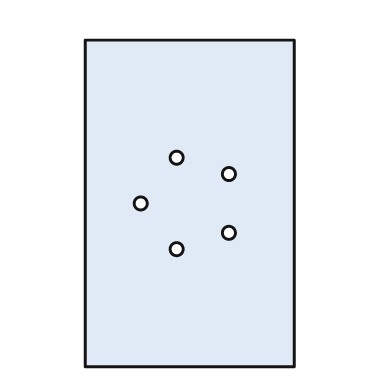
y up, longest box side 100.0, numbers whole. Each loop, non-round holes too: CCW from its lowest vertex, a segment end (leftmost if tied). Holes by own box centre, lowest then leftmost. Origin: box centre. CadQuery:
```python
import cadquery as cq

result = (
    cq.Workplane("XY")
    .moveTo(-32.0, -50.0)
    .lineTo(32.0, -50.0)
    .lineTo(32.0, 50.0)
    .lineTo(-32.0, 50.0)
    .close()
    .moveTo(-4.0, -14.0)
    .circle(2.0)
    .moveTo(12.0, -9.0)
    .circle(2.0)
    .moveTo(-15.0, 0.0)
    .circle(2.0)
    .moveTo(12.0, 9.0)
    .circle(2.0)
    .moveTo(-4.0, 14.0)
    .circle(2.0)
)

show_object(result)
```